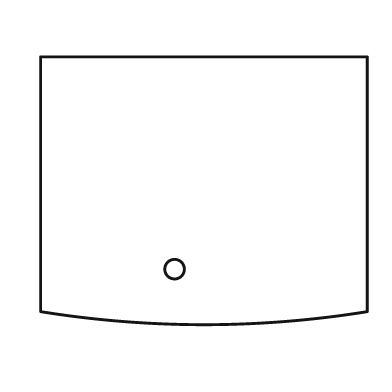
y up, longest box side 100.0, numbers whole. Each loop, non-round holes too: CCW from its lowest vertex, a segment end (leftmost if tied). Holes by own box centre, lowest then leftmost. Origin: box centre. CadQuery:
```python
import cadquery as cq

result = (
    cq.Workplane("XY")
    .moveTo(-50.0, -37.0)
    .threePointArc((0.0, -41.0), (50.0, -37.0))
    .lineTo(50.0, 41.0)
    .lineTo(-50.0, 41.0)
    .close()
    .moveTo(-9.0, -24.0)
    .circle(3.0)
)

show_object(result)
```